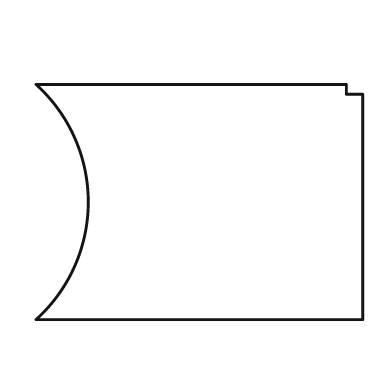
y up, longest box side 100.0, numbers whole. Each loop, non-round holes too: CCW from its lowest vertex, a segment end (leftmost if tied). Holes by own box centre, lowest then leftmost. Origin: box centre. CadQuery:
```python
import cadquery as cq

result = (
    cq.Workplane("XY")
    .moveTo(-50.0, -36.0)
    .lineTo(50.0, -36.0)
    .lineTo(50.0, 33.0)
    .lineTo(45.0, 33.0)
    .lineTo(45.0, 36.0)
    .lineTo(-50.0, 36.0)
    .threePointArc((-34.0, 0.0), (-50.0, -36.0))
    .close()
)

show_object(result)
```